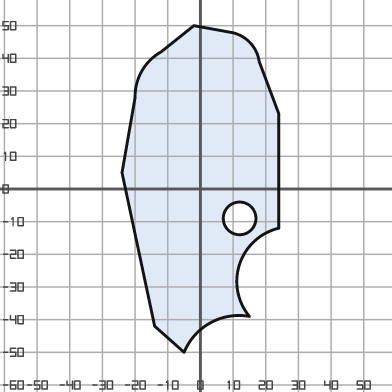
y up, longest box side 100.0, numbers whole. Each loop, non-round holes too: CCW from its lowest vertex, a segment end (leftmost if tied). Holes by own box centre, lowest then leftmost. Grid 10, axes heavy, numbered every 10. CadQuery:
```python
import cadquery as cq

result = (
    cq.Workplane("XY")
    .moveTo(-5.0, -50.0)
    .threePointArc((3.0, -41.0), (15.0, -39.0))
    .threePointArc((12.0, -23.0), (24.0, -12.0))
    .lineTo(24.0, 23.0)
    .lineTo(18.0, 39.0)
    .threePointArc((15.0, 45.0), (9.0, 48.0))
    .lineTo(-2.0, 50.0)
    .lineTo(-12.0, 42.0)
    .threePointArc((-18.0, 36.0), (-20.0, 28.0))
    .lineTo(-24.0, 5.0)
    .lineTo(-14.0, -42.0)
    .close()
    .moveTo(12.0, -9.0)
    .circle(5.0)
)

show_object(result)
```